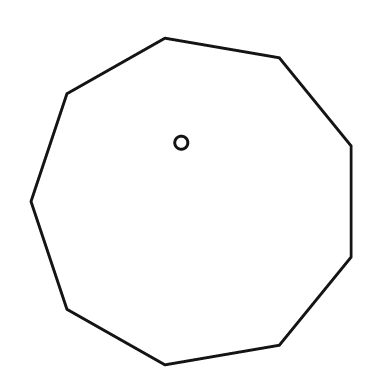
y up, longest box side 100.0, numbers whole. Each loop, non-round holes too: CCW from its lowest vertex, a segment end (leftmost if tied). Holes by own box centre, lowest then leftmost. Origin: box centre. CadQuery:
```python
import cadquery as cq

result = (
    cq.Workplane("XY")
    .moveTo(-8.0, -50.0)
    .lineTo(27.0, -44.0)
    .lineTo(49.0, -17.0)
    .lineTo(49.0, 17.0)
    .lineTo(27.0, 44.0)
    .lineTo(-8.0, 50.0)
    .lineTo(-38.0, 33.0)
    .lineTo(-49.0, 0.0)
    .lineTo(-38.0, -33.0)
    .close()
    .moveTo(-3.0, 18.0)
    .circle(2.0)
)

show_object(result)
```